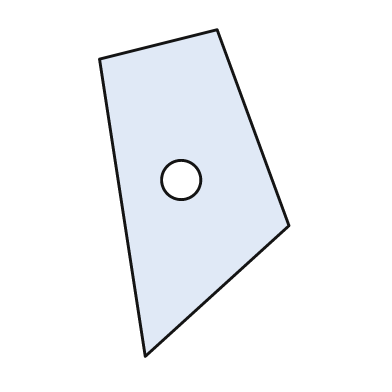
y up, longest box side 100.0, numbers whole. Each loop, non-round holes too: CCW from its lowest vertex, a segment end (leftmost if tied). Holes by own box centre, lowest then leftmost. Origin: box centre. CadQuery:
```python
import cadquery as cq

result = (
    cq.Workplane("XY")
    .moveTo(-15.0, -50.0)
    .lineTo(29.0, -10.0)
    .lineTo(7.0, 50.0)
    .lineTo(-29.0, 41.0)
    .close()
    .moveTo(-4.0, 4.0)
    .circle(6.0)
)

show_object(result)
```